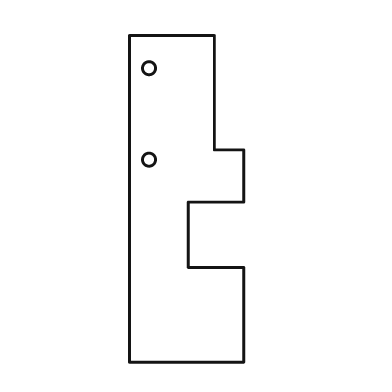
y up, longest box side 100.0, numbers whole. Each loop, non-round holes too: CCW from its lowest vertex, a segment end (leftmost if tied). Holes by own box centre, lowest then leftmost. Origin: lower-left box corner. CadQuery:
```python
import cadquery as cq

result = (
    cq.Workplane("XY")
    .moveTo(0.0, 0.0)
    .lineTo(35.0, 0.0)
    .lineTo(35.0, 29.0)
    .lineTo(18.0, 29.0)
    .lineTo(18.0, 49.0)
    .lineTo(35.0, 49.0)
    .lineTo(35.0, 65.0)
    .lineTo(26.0, 65.0)
    .lineTo(26.0, 100.0)
    .lineTo(0.0, 100.0)
    .close()
    .moveTo(6.0, 62.0)
    .circle(2.0)
    .moveTo(6.0, 90.0)
    .circle(2.0)
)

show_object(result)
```